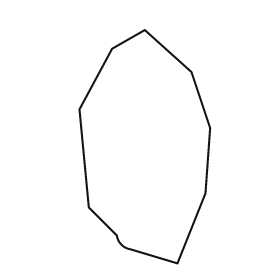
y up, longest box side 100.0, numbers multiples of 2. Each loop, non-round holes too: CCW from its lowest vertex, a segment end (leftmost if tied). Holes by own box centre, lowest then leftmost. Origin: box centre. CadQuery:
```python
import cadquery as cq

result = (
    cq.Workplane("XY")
    .moveTo(14.0, -50.0)
    .lineTo(26.0, -20.0)
    .lineTo(28.0, 8.0)
    .lineTo(20.0, 32.0)
    .lineTo(0.0, 50.0)
    .lineTo(-14.0, 42.0)
    .lineTo(-28.0, 16.0)
    .lineTo(-24.0, -26.0)
    .lineTo(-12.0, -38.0)
    .threePointArc((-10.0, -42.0), (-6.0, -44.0))
    .close()
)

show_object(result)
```